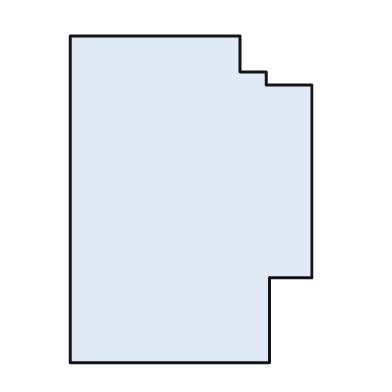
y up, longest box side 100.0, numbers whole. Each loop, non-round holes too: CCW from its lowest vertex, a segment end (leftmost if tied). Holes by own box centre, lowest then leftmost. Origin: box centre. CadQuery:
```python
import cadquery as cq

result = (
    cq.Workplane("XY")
    .moveTo(-37.0, -50.0)
    .lineTo(24.0, -50.0)
    .lineTo(24.0, -24.0)
    .lineTo(37.0, -24.0)
    .lineTo(37.0, 35.0)
    .lineTo(23.0, 35.0)
    .lineTo(23.0, 39.0)
    .lineTo(15.0, 39.0)
    .lineTo(15.0, 50.0)
    .lineTo(-37.0, 50.0)
    .close()
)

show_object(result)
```